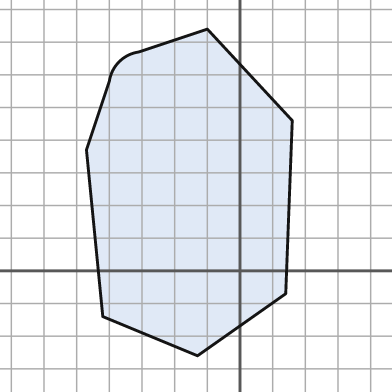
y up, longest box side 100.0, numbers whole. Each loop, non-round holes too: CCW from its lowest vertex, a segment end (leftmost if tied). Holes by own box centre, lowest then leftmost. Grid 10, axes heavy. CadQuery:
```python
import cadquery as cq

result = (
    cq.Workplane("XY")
    .moveTo(-13.0, -26.0)
    .lineTo(14.0, -7.0)
    .lineTo(16.0, 46.0)
    .lineTo(-10.0, 74.0)
    .lineTo(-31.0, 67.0)
    .threePointArc((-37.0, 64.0), (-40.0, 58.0))
    .lineTo(-47.0, 37.0)
    .lineTo(-42.0, -14.0)
    .close()
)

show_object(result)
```